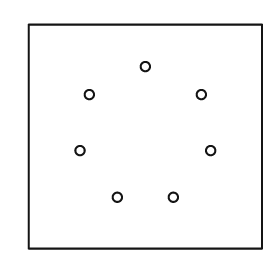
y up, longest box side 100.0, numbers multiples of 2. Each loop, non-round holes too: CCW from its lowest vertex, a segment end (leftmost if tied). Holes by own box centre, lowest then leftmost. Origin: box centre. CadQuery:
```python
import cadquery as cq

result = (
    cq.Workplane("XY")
    .moveTo(-50.0, -48.0)
    .lineTo(50.0, -48.0)
    .lineTo(50.0, 48.0)
    .lineTo(-50.0, 48.0)
    .close()
    .moveTo(-12.0, -26.0)
    .circle(2.0)
    .moveTo(12.0, -26.0)
    .circle(2.0)
    .moveTo(-28.0, -6.0)
    .circle(2.0)
    .moveTo(28.0, -6.0)
    .circle(2.0)
    .moveTo(-24.0, 18.0)
    .circle(2.0)
    .moveTo(24.0, 18.0)
    .circle(2.0)
    .moveTo(0.0, 30.0)
    .circle(2.0)
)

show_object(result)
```